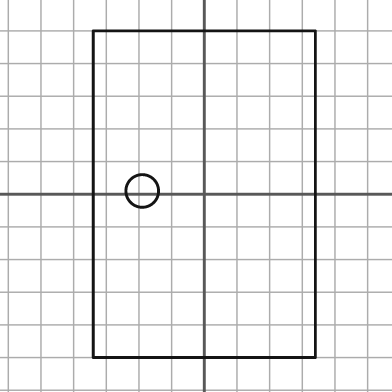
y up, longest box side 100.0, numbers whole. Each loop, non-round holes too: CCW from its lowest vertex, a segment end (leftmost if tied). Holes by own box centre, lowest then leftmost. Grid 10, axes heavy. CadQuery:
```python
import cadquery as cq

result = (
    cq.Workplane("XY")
    .moveTo(-34.0, -50.0)
    .lineTo(34.0, -50.0)
    .lineTo(34.0, 50.0)
    .lineTo(-34.0, 50.0)
    .close()
    .moveTo(-19.0, 1.0)
    .circle(5.0)
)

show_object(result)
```